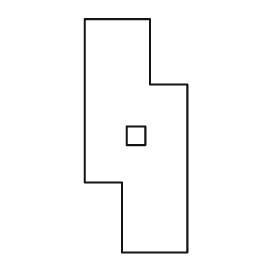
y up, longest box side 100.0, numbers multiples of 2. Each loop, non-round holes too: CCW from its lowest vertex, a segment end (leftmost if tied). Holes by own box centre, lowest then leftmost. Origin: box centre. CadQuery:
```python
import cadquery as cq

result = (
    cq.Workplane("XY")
    .moveTo(-6.0, -50.0)
    .lineTo(22.0, -50.0)
    .lineTo(22.0, 22.0)
    .lineTo(6.0, 22.0)
    .lineTo(6.0, 50.0)
    .lineTo(-22.0, 50.0)
    .lineTo(-22.0, -20.0)
    .lineTo(-6.0, -20.0)
    .close()
    .moveTo(-4.0, -4.0)
    .lineTo(4.0, -4.0)
    .lineTo(4.0, 4.0)
    .lineTo(-4.0, 4.0)
    .close()
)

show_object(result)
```